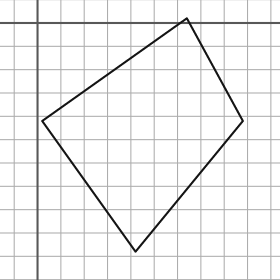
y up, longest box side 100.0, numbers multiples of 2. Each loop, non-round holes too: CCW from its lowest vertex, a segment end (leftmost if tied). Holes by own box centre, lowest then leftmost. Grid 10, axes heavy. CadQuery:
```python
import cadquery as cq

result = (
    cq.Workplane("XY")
    .moveTo(42.0, -98.0)
    .lineTo(88.0, -42.0)
    .lineTo(64.0, 2.0)
    .lineTo(2.0, -42.0)
    .close()
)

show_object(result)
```